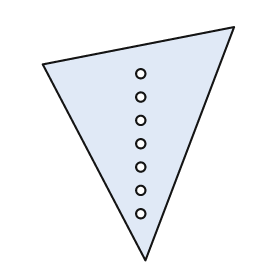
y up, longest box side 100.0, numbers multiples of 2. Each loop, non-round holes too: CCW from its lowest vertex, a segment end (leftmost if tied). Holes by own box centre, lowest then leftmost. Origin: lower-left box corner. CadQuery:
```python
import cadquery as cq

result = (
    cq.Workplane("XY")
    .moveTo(44.0, 0.0)
    .lineTo(82.0, 100.0)
    .lineTo(0.0, 84.0)
    .close()
    .moveTo(42.0, 20.0)
    .circle(2.0)
    .moveTo(42.0, 30.0)
    .circle(2.0)
    .moveTo(42.0, 40.0)
    .circle(2.0)
    .moveTo(42.0, 50.0)
    .circle(2.0)
    .moveTo(42.0, 60.0)
    .circle(2.0)
    .moveTo(42.0, 70.0)
    .circle(2.0)
    .moveTo(42.0, 80.0)
    .circle(2.0)
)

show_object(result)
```